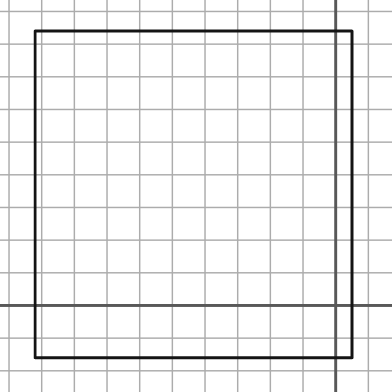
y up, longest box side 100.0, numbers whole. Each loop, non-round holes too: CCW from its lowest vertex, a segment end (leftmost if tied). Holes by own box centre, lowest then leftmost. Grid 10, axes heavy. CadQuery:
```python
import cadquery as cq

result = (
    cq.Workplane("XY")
    .moveTo(-92.0, -16.0)
    .lineTo(5.0, -16.0)
    .lineTo(5.0, 84.0)
    .lineTo(-92.0, 84.0)
    .close()
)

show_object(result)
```